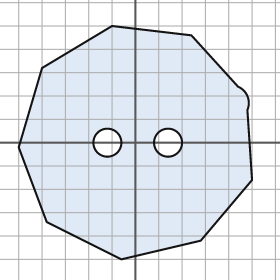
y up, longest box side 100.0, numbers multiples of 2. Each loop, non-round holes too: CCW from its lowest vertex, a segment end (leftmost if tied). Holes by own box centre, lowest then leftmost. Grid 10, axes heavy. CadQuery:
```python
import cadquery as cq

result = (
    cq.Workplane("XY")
    .moveTo(-6.0, -50.0)
    .lineTo(28.0, -42.0)
    .lineTo(50.0, -16.0)
    .lineTo(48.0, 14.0)
    .threePointArc((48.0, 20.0), (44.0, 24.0))
    .lineTo(24.0, 46.0)
    .lineTo(-10.0, 50.0)
    .lineTo(-40.0, 32.0)
    .lineTo(-50.0, -2.0)
    .lineTo(-38.0, -34.0)
    .close()
    .moveTo(-12.0, 0.0)
    .circle(6.0)
    .moveTo(14.0, 0.0)
    .circle(6.0)
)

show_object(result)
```